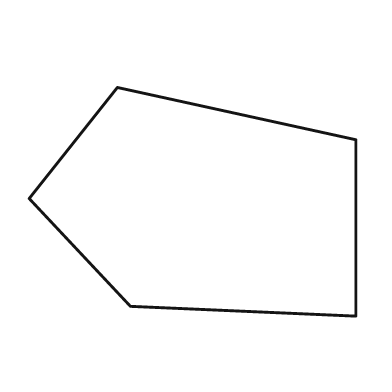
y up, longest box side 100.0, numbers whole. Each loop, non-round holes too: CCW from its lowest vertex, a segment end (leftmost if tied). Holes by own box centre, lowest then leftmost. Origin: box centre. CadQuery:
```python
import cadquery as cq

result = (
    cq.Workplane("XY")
    .moveTo(50.0, -35.0)
    .lineTo(50.0, 19.0)
    .lineTo(-23.0, 35.0)
    .lineTo(-50.0, 1.0)
    .lineTo(-19.0, -32.0)
    .close()
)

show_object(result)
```